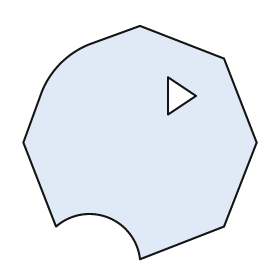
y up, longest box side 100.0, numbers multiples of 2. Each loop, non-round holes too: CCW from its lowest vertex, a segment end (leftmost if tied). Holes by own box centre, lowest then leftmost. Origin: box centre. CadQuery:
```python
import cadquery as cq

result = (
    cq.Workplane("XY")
    .moveTo(0.0, -50.0)
    .lineTo(36.0, -36.0)
    .lineTo(50.0, 0.0)
    .lineTo(36.0, 36.0)
    .lineTo(0.0, 50.0)
    .lineTo(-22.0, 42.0)
    .threePointArc((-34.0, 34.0), (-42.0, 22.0))
    .lineTo(-50.0, 0.0)
    .lineTo(-36.0, -36.0)
    .threePointArc((-14.0, -32.0), (0.0, -50.0))
    .close()
    .moveTo(12.0, 12.0)
    .lineTo(24.0, 20.0)
    .lineTo(12.0, 28.0)
    .close()
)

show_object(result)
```